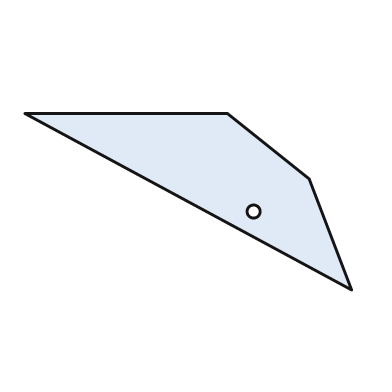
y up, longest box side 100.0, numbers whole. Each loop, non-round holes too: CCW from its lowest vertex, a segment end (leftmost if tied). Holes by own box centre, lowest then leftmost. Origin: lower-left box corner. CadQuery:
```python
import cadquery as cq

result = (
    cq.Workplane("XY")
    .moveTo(100.0, 0.0)
    .lineTo(87.0, 34.0)
    .lineTo(62.0, 54.0)
    .lineTo(0.0, 54.0)
    .close()
    .moveTo(70.0, 24.0)
    .circle(2.0)
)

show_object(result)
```